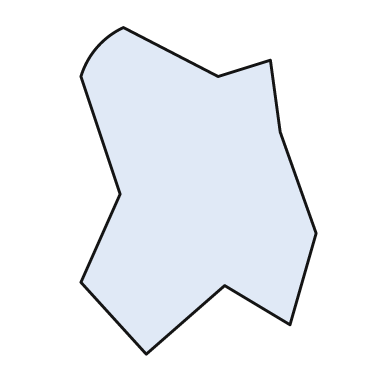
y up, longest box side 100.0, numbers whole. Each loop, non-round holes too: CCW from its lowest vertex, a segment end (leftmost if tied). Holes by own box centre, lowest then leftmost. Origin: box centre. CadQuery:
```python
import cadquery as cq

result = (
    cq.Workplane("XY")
    .moveTo(-16.0, -50.0)
    .lineTo(8.0, -29.0)
    .lineTo(28.0, -41.0)
    .lineTo(36.0, -13.0)
    .lineTo(25.0, 18.0)
    .lineTo(22.0, 40.0)
    .lineTo(6.0, 35.0)
    .lineTo(-23.0, 50.0)
    .threePointArc((-31.0, 44.0), (-36.0, 35.0))
    .lineTo(-24.0, -1.0)
    .lineTo(-36.0, -28.0)
    .close()
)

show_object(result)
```